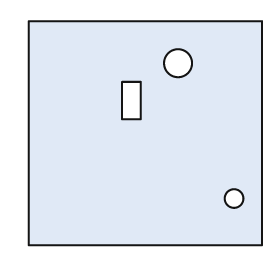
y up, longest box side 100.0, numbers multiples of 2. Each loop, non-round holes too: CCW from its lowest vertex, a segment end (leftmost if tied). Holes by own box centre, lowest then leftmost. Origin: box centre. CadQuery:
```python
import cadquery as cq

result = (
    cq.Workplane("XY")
    .moveTo(-50.0, -48.0)
    .lineTo(50.0, -48.0)
    .lineTo(50.0, 48.0)
    .lineTo(-50.0, 48.0)
    .close()
    .moveTo(38.0, -28.0)
    .circle(4.0)
    .moveTo(-10.0, 6.0)
    .lineTo(-2.0, 6.0)
    .lineTo(-2.0, 22.0)
    .lineTo(-10.0, 22.0)
    .close()
    .moveTo(14.0, 30.0)
    .circle(6.0)
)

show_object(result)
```